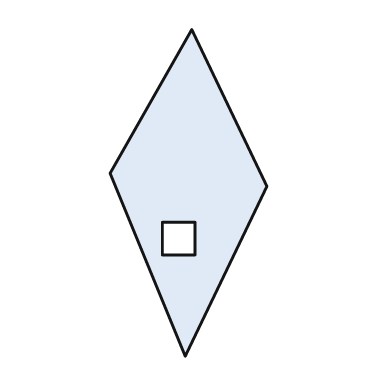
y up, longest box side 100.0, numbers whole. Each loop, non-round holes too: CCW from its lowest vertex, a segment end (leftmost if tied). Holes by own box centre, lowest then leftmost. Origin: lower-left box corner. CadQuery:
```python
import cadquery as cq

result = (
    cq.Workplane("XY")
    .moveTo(23.0, 0.0)
    .lineTo(48.0, 52.0)
    .lineTo(25.0, 100.0)
    .lineTo(0.0, 56.0)
    .close()
    .moveTo(16.0, 31.0)
    .lineTo(26.0, 31.0)
    .lineTo(26.0, 41.0)
    .lineTo(16.0, 41.0)
    .close()
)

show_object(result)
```